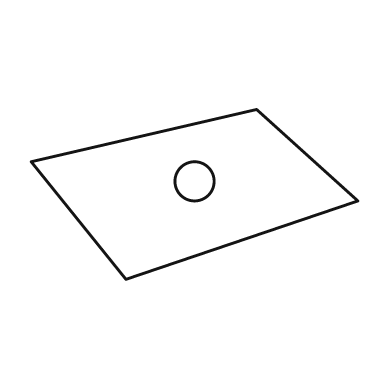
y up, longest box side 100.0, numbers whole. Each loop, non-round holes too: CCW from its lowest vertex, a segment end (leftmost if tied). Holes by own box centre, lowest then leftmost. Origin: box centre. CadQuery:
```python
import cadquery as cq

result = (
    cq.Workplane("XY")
    .moveTo(-21.0, -26.0)
    .lineTo(50.0, -2.0)
    .lineTo(19.0, 26.0)
    .lineTo(-50.0, 10.0)
    .close()
    .moveTo(0.0, 4.0)
    .circle(6.0)
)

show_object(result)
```